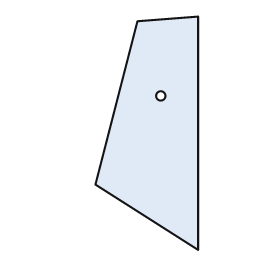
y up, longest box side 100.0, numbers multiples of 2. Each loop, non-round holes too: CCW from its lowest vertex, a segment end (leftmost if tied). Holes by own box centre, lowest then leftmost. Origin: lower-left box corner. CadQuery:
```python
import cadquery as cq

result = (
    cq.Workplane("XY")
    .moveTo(44.0, 0.0)
    .lineTo(44.0, 100.0)
    .lineTo(18.0, 98.0)
    .lineTo(0.0, 28.0)
    .close()
    .moveTo(28.0, 66.0)
    .circle(2.0)
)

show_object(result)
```